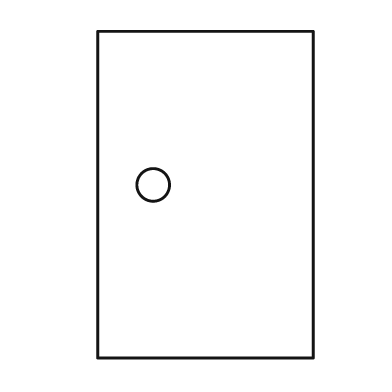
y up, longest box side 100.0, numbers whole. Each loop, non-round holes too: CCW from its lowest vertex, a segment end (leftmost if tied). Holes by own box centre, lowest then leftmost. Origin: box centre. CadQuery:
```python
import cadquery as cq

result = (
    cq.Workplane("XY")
    .moveTo(-33.0, -50.0)
    .lineTo(33.0, -50.0)
    .lineTo(33.0, 50.0)
    .lineTo(-33.0, 50.0)
    .close()
    .moveTo(-16.0, 3.0)
    .circle(5.0)
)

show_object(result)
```